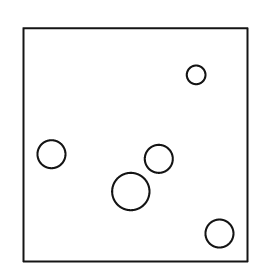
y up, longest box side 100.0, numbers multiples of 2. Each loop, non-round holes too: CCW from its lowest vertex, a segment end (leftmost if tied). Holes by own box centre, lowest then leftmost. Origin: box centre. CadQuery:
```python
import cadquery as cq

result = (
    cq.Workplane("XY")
    .moveTo(-48.0, -50.0)
    .lineTo(48.0, -50.0)
    .lineTo(48.0, 50.0)
    .lineTo(-48.0, 50.0)
    .close()
    .moveTo(36.0, -38.0)
    .circle(6.0)
    .moveTo(-2.0, -20.0)
    .circle(8.0)
    .moveTo(10.0, -6.0)
    .circle(6.0)
    .moveTo(-36.0, -4.0)
    .circle(6.0)
    .moveTo(26.0, 30.0)
    .circle(4.0)
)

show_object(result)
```